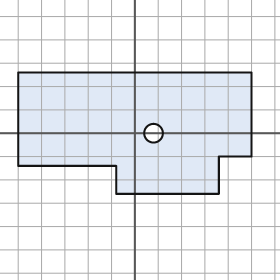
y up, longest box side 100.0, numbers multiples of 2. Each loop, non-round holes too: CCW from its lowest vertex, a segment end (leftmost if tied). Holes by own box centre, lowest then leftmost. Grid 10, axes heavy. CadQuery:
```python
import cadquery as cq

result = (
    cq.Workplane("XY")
    .moveTo(-8.0, -26.0)
    .lineTo(36.0, -26.0)
    .lineTo(36.0, -10.0)
    .lineTo(50.0, -10.0)
    .lineTo(50.0, 26.0)
    .lineTo(-50.0, 26.0)
    .lineTo(-50.0, -14.0)
    .lineTo(-8.0, -14.0)
    .close()
    .moveTo(8.0, 0.0)
    .circle(4.0)
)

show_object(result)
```